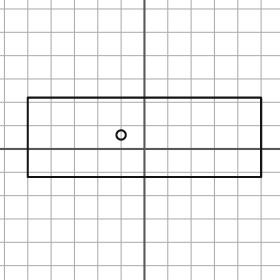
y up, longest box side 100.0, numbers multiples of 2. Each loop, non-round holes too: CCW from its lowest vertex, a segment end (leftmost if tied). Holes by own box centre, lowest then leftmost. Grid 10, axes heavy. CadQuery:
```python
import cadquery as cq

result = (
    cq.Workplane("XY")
    .moveTo(-50.0, -12.0)
    .lineTo(50.0, -12.0)
    .lineTo(50.0, 22.0)
    .lineTo(-50.0, 22.0)
    .close()
    .moveTo(-10.0, 6.0)
    .circle(2.0)
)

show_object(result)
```